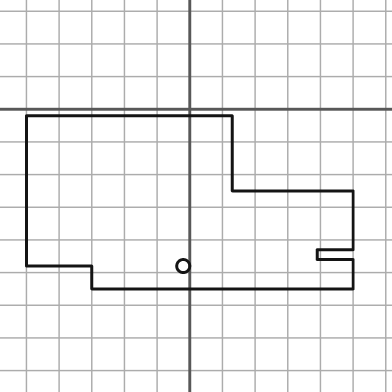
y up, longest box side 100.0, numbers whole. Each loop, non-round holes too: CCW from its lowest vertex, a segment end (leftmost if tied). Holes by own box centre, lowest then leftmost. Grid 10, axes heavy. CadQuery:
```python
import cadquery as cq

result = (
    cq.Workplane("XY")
    .moveTo(-30.0, -55.0)
    .lineTo(50.0, -55.0)
    .lineTo(50.0, -46.0)
    .lineTo(39.0, -46.0)
    .lineTo(39.0, -43.0)
    .lineTo(50.0, -43.0)
    .lineTo(50.0, -25.0)
    .lineTo(13.0, -25.0)
    .lineTo(13.0, -2.0)
    .lineTo(-50.0, -2.0)
    .lineTo(-50.0, -48.0)
    .lineTo(-30.0, -48.0)
    .close()
    .moveTo(-2.0, -48.0)
    .circle(2.0)
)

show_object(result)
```